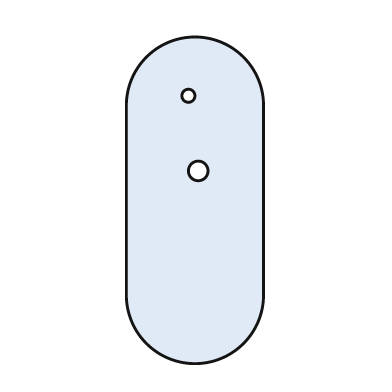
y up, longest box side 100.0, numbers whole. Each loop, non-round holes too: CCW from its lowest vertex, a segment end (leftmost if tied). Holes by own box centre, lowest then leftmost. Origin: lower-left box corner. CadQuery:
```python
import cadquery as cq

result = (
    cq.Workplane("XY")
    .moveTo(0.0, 21.0)
    .threePointArc((21.0, 0.0), (42.0, 21.0))
    .lineTo(42.0, 79.0)
    .threePointArc((21.0, 100.0), (0.0, 79.0))
    .close()
    .moveTo(22.0, 59.0)
    .circle(3.0)
    .moveTo(19.0, 82.0)
    .circle(2.0)
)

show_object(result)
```